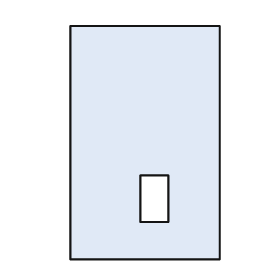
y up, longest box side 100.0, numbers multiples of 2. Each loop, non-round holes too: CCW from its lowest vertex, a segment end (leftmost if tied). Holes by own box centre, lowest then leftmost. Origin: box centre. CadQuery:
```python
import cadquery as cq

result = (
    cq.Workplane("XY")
    .moveTo(-32.0, -50.0)
    .lineTo(32.0, -50.0)
    .lineTo(32.0, 50.0)
    .lineTo(-32.0, 50.0)
    .close()
    .moveTo(-2.0, -34.0)
    .lineTo(10.0, -34.0)
    .lineTo(10.0, -14.0)
    .lineTo(-2.0, -14.0)
    .close()
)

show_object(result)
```